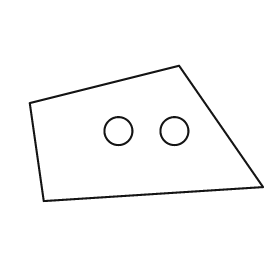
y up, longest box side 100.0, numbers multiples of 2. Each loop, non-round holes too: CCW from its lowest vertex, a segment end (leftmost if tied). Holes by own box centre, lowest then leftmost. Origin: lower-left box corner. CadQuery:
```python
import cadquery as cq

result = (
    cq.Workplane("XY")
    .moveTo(6.0, 0.0)
    .lineTo(100.0, 6.0)
    .lineTo(64.0, 58.0)
    .lineTo(0.0, 42.0)
    .close()
    .moveTo(38.0, 30.0)
    .circle(6.0)
    .moveTo(62.0, 30.0)
    .circle(6.0)
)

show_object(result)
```